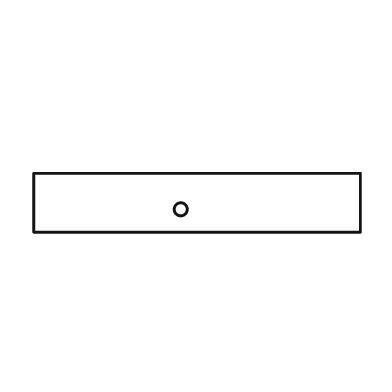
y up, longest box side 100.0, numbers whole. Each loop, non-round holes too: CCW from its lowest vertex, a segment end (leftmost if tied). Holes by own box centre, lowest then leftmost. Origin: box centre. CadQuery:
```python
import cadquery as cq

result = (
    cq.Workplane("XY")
    .moveTo(-50.0, -9.0)
    .lineTo(50.0, -9.0)
    .lineTo(50.0, 9.0)
    .lineTo(-50.0, 9.0)
    .close()
    .moveTo(-5.0, -2.0)
    .circle(2.0)
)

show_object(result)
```